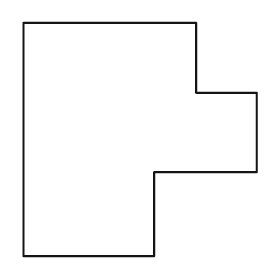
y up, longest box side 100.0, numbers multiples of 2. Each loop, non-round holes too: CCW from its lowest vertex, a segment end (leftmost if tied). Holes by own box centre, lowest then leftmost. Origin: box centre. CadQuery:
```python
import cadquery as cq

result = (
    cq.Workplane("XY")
    .moveTo(-50.0, -50.0)
    .lineTo(6.0, -50.0)
    .lineTo(6.0, -14.0)
    .lineTo(50.0, -14.0)
    .lineTo(50.0, 20.0)
    .lineTo(24.0, 20.0)
    .lineTo(24.0, 50.0)
    .lineTo(-50.0, 50.0)
    .close()
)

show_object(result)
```